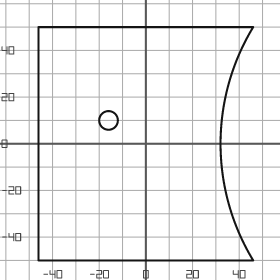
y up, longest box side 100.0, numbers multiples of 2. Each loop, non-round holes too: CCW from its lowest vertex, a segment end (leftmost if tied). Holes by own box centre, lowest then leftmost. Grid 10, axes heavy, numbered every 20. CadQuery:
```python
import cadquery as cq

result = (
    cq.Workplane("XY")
    .moveTo(-46.0, -50.0)
    .lineTo(46.0, -50.0)
    .threePointArc((32.0, 0.0), (46.0, 50.0))
    .lineTo(-46.0, 50.0)
    .close()
    .moveTo(-16.0, 10.0)
    .circle(4.0)
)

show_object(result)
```